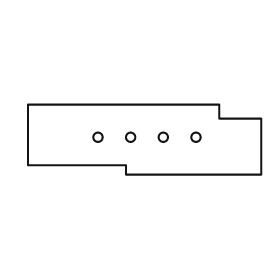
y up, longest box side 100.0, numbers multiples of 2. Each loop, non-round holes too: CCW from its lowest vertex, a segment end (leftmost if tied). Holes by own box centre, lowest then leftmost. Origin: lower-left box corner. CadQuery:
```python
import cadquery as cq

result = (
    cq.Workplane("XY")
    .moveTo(42.0, 0.0)
    .lineTo(100.0, 0.0)
    .lineTo(100.0, 24.0)
    .lineTo(82.0, 24.0)
    .lineTo(82.0, 30.0)
    .lineTo(0.0, 30.0)
    .lineTo(0.0, 4.0)
    .lineTo(42.0, 4.0)
    .close()
    .moveTo(30.0, 16.0)
    .circle(2.0)
    .moveTo(44.0, 16.0)
    .circle(2.0)
    .moveTo(58.0, 16.0)
    .circle(2.0)
    .moveTo(72.0, 16.0)
    .circle(2.0)
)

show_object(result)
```